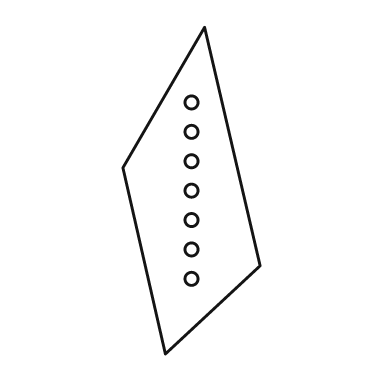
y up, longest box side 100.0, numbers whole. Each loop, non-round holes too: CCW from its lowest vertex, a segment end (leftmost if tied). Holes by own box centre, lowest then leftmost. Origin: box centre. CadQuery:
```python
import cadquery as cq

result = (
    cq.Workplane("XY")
    .moveTo(-8.0, -50.0)
    .lineTo(21.0, -23.0)
    .lineTo(4.0, 50.0)
    .lineTo(-21.0, 7.0)
    .close()
    .moveTo(0.0, -27.0)
    .circle(2.0)
    .moveTo(0.0, -18.0)
    .circle(2.0)
    .moveTo(0.0, -9.0)
    .circle(2.0)
    .moveTo(0.0, 0.0)
    .circle(2.0)
    .moveTo(0.0, 9.0)
    .circle(2.0)
    .moveTo(0.0, 18.0)
    .circle(2.0)
    .moveTo(0.0, 27.0)
    .circle(2.0)
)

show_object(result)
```